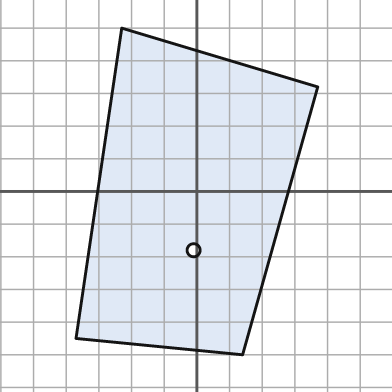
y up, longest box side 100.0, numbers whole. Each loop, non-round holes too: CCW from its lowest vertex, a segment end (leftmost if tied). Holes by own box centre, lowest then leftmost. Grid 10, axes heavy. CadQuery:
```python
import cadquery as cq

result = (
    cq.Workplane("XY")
    .moveTo(14.0, -50.0)
    .lineTo(37.0, 32.0)
    .lineTo(-23.0, 50.0)
    .lineTo(-37.0, -45.0)
    .close()
    .moveTo(-1.0, -18.0)
    .circle(2.0)
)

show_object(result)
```